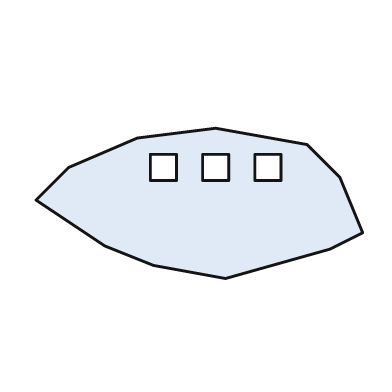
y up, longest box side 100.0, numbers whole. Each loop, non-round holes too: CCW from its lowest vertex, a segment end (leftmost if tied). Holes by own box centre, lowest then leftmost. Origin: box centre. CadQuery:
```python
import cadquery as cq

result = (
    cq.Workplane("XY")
    .moveTo(8.0, -23.0)
    .lineTo(40.0, -14.0)
    .lineTo(50.0, -9.0)
    .lineTo(43.0, 8.0)
    .lineTo(33.0, 18.0)
    .lineTo(5.0, 23.0)
    .lineTo(-19.0, 20.0)
    .lineTo(-40.0, 11.0)
    .lineTo(-50.0, 1.0)
    .lineTo(-29.0, -13.0)
    .lineTo(-14.0, -19.0)
    .close()
    .moveTo(-15.0, 7.0)
    .lineTo(-7.0, 7.0)
    .lineTo(-7.0, 15.0)
    .lineTo(-15.0, 15.0)
    .close()
    .moveTo(1.0, 7.0)
    .lineTo(9.0, 7.0)
    .lineTo(9.0, 15.0)
    .lineTo(1.0, 15.0)
    .close()
    .moveTo(17.0, 7.0)
    .lineTo(25.0, 7.0)
    .lineTo(25.0, 15.0)
    .lineTo(17.0, 15.0)
    .close()
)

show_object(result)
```